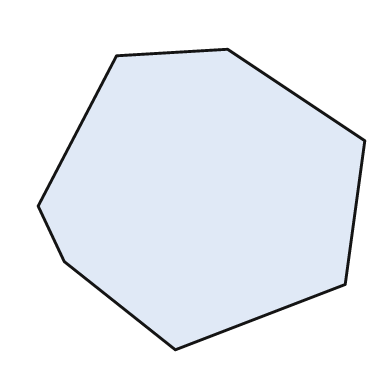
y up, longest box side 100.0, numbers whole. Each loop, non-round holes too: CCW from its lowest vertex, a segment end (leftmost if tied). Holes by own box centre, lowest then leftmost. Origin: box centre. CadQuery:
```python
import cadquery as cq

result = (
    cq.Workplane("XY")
    .moveTo(-8.0, -46.0)
    .lineTo(44.0, -26.0)
    .lineTo(50.0, 18.0)
    .lineTo(8.0, 46.0)
    .lineTo(-26.0, 44.0)
    .lineTo(-50.0, -2.0)
    .lineTo(-42.0, -19.0)
    .close()
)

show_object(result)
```